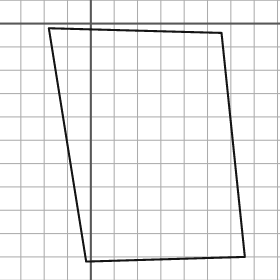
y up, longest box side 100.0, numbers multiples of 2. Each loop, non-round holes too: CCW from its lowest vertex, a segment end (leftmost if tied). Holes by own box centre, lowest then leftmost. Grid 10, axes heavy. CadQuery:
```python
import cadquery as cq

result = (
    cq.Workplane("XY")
    .moveTo(-2.0, -102.0)
    .lineTo(66.0, -100.0)
    .lineTo(56.0, -4.0)
    .lineTo(-18.0, -2.0)
    .close()
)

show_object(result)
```